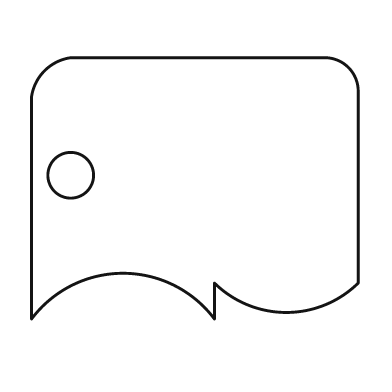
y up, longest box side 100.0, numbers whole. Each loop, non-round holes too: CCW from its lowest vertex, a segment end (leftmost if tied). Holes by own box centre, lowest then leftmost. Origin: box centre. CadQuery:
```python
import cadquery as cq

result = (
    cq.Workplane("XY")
    .moveTo(-50.0, -40.0)
    .threePointArc((-22.0, -26.0), (6.0, -40.0))
    .lineTo(6.0, -29.0)
    .threePointArc((28.0, -38.0), (50.0, -29.0))
    .lineTo(50.0, 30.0)
    .threePointArc((47.0, 37.0), (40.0, 40.0))
    .lineTo(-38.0, 40.0)
    .threePointArc((-46.0, 36.0), (-50.0, 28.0))
    .close()
    .moveTo(-38.0, 4.0)
    .circle(7.0)
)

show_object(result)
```